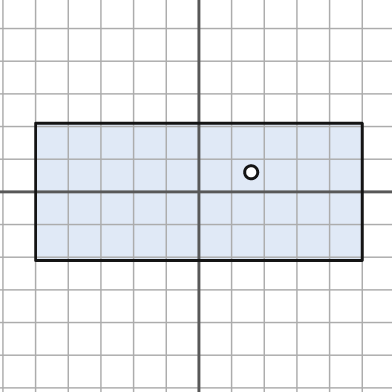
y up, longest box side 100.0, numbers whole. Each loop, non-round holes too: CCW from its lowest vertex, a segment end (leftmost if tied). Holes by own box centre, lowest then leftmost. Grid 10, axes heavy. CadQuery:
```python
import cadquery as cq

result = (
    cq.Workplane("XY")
    .moveTo(-50.0, -21.0)
    .lineTo(50.0, -21.0)
    .lineTo(50.0, 21.0)
    .lineTo(-50.0, 21.0)
    .close()
    .moveTo(16.0, 6.0)
    .circle(2.0)
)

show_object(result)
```